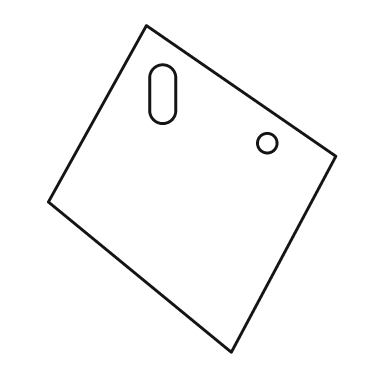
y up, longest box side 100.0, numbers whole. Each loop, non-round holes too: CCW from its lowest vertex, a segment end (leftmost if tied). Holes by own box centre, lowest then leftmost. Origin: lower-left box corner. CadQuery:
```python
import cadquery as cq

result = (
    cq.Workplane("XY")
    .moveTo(56.0, 0.0)
    .lineTo(88.0, 60.0)
    .lineTo(30.0, 100.0)
    .lineTo(0.0, 46.0)
    .close()
    .moveTo(67.0, 64.0)
    .circle(3.0)
    .moveTo(31.0, 74.0)
    .threePointArc((35.0, 70.0), (39.0, 74.0))
    .lineTo(39.0, 84.0)
    .threePointArc((35.0, 88.0), (31.0, 84.0))
    .close()
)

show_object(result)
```